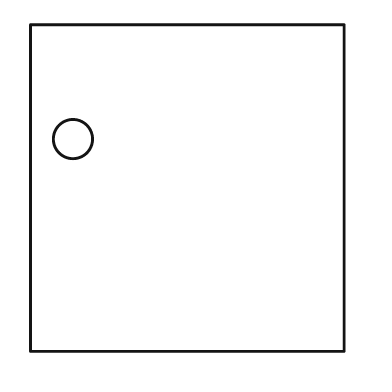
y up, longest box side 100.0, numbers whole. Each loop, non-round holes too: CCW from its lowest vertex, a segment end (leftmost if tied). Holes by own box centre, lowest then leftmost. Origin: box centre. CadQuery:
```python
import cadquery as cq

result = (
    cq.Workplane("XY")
    .moveTo(-48.0, -50.0)
    .lineTo(48.0, -50.0)
    .lineTo(48.0, 50.0)
    .lineTo(-48.0, 50.0)
    .close()
    .moveTo(-35.0, 15.0)
    .circle(6.0)
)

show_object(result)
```